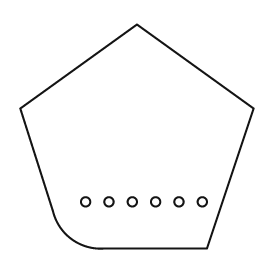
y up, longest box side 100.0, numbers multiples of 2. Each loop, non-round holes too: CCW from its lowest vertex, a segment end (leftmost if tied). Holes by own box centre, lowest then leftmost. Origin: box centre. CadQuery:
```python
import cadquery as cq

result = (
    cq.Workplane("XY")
    .moveTo(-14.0, -48.0)
    .lineTo(30.0, -48.0)
    .lineTo(50.0, 12.0)
    .lineTo(0.0, 48.0)
    .lineTo(-50.0, 12.0)
    .lineTo(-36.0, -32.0)
    .threePointArc((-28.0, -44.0), (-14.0, -48.0))
    .close()
    .moveTo(-22.0, -28.0)
    .circle(2.0)
    .moveTo(-12.0, -28.0)
    .circle(2.0)
    .moveTo(-2.0, -28.0)
    .circle(2.0)
    .moveTo(8.0, -28.0)
    .circle(2.0)
    .moveTo(18.0, -28.0)
    .circle(2.0)
    .moveTo(28.0, -28.0)
    .circle(2.0)
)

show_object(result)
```